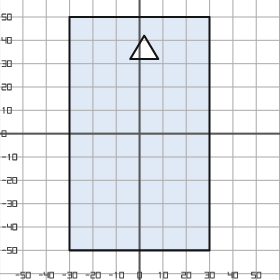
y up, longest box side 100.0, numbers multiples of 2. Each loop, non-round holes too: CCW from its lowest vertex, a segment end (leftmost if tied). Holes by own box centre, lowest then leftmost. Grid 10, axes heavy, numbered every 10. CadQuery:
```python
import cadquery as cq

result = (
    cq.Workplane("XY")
    .moveTo(-30.0, -50.0)
    .lineTo(30.0, -50.0)
    .lineTo(30.0, 50.0)
    .lineTo(-30.0, 50.0)
    .close()
    .moveTo(-4.0, 32.0)
    .lineTo(8.0, 32.0)
    .lineTo(2.0, 42.0)
    .close()
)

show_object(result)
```